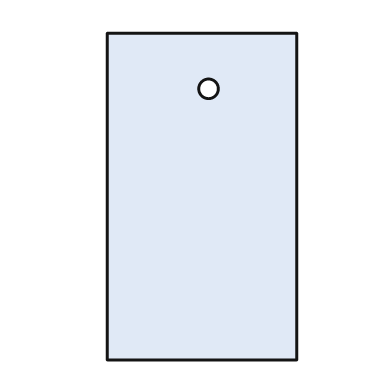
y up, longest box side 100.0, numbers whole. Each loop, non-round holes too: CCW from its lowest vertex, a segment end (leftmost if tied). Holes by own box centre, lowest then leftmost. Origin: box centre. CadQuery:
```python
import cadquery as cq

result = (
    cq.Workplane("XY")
    .moveTo(-29.0, -50.0)
    .lineTo(29.0, -50.0)
    .lineTo(29.0, 50.0)
    .lineTo(-29.0, 50.0)
    .close()
    .moveTo(2.0, 33.0)
    .circle(3.0)
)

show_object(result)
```